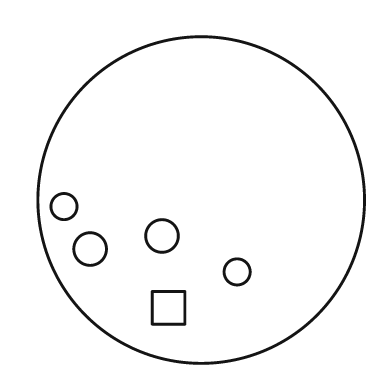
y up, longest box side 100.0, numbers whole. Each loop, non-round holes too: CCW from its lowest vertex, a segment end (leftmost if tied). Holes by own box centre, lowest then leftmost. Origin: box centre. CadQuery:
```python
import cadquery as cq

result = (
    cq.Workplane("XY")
    .moveTo(0.0, 0.0)
    .circle(50.0)
    .moveTo(-15.0, -38.0)
    .lineTo(-5.0, -38.0)
    .lineTo(-5.0, -28.0)
    .lineTo(-15.0, -28.0)
    .close()
    .moveTo(11.0, -22.0)
    .circle(4.0)
    .moveTo(-34.0, -15.0)
    .circle(5.0)
    .moveTo(-12.0, -11.0)
    .circle(5.0)
    .moveTo(-42.0, -2.0)
    .circle(4.0)
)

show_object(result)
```